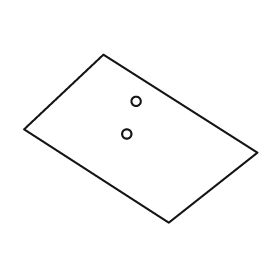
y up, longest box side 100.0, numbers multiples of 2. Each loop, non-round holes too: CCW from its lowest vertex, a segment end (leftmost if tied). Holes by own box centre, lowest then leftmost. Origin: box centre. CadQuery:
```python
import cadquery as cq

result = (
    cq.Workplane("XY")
    .moveTo(12.0, -36.0)
    .lineTo(50.0, -6.0)
    .lineTo(-16.0, 36.0)
    .lineTo(-50.0, 4.0)
    .close()
    .moveTo(-6.0, 2.0)
    .circle(2.0)
    .moveTo(-2.0, 16.0)
    .circle(2.0)
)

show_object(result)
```